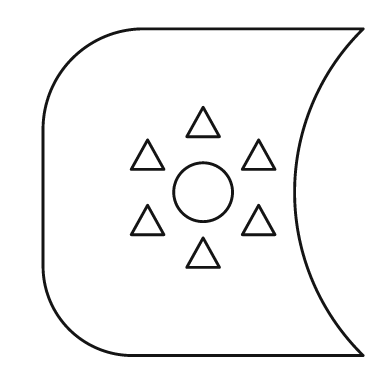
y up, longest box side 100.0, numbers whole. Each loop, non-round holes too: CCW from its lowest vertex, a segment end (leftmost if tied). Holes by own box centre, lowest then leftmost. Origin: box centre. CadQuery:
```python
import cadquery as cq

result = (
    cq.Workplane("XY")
    .moveTo(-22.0, -50.0)
    .lineTo(49.0, -50.0)
    .threePointArc((28.0, 0.0), (49.0, 50.0))
    .lineTo(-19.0, 50.0)
    .threePointArc((-40.0, 41.0), (-49.0, 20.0))
    .lineTo(-49.0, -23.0)
    .threePointArc((-41.0, -42.0), (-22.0, -50.0))
    .close()
    .moveTo(-5.0, -23.0)
    .lineTo(5.0, -23.0)
    .lineTo(0.0, -14.0)
    .close()
    .moveTo(-22.0, -13.0)
    .lineTo(-12.0, -13.0)
    .lineTo(-17.0, -4.0)
    .close()
    .moveTo(12.0, -13.0)
    .lineTo(22.0, -13.0)
    .lineTo(17.0, -4.0)
    .close()
    .moveTo(0.0, 0.0)
    .circle(9.0)
    .moveTo(-22.0, 7.0)
    .lineTo(-12.0, 7.0)
    .lineTo(-17.0, 16.0)
    .close()
    .moveTo(12.0, 7.0)
    .lineTo(22.0, 7.0)
    .lineTo(17.0, 16.0)
    .close()
    .moveTo(-5.0, 17.0)
    .lineTo(5.0, 17.0)
    .lineTo(0.0, 26.0)
    .close()
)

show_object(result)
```